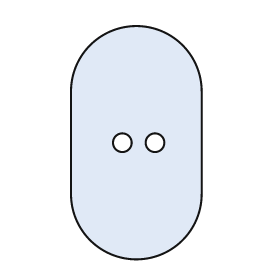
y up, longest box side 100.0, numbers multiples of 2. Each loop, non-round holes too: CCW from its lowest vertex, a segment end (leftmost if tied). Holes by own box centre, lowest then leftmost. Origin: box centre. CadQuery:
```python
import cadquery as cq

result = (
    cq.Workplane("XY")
    .moveTo(-28.0, -22.0)
    .threePointArc((0.0, -50.0), (28.0, -22.0))
    .lineTo(28.0, 22.0)
    .threePointArc((0.0, 50.0), (-28.0, 22.0))
    .close()
    .moveTo(-6.0, 0.0)
    .circle(4.0)
    .moveTo(8.0, 0.0)
    .circle(4.0)
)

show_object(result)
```